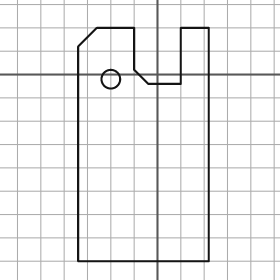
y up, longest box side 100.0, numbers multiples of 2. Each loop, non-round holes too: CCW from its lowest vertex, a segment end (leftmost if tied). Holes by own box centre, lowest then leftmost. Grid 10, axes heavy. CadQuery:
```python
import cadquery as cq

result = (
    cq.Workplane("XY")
    .moveTo(-34.0, -80.0)
    .lineTo(22.0, -80.0)
    .lineTo(22.0, 20.0)
    .lineTo(10.0, 20.0)
    .lineTo(10.0, -4.0)
    .lineTo(-4.0, -4.0)
    .lineTo(-10.0, 2.0)
    .lineTo(-10.0, 20.0)
    .lineTo(-26.0, 20.0)
    .lineTo(-34.0, 12.0)
    .close()
    .moveTo(-20.0, -2.0)
    .circle(4.0)
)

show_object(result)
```